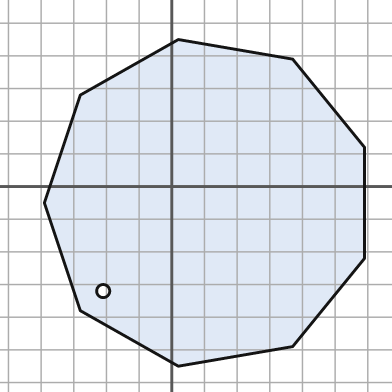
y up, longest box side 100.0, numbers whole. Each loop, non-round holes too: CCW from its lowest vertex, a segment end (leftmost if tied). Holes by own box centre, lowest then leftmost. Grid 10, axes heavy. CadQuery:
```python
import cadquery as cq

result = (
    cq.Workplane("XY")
    .moveTo(2.0, -55.0)
    .lineTo(37.0, -49.0)
    .lineTo(59.0, -22.0)
    .lineTo(59.0, 12.0)
    .lineTo(37.0, 39.0)
    .lineTo(2.0, 45.0)
    .lineTo(-28.0, 28.0)
    .lineTo(-39.0, -5.0)
    .lineTo(-28.0, -38.0)
    .close()
    .moveTo(-21.0, -32.0)
    .circle(2.0)
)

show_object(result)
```